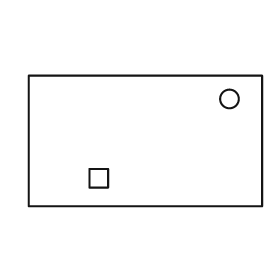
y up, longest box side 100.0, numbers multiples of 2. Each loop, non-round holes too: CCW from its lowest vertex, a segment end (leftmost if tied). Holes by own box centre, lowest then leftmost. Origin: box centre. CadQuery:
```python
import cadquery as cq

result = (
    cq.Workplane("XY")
    .moveTo(-50.0, -28.0)
    .lineTo(50.0, -28.0)
    .lineTo(50.0, 28.0)
    .lineTo(-50.0, 28.0)
    .close()
    .moveTo(-24.0, -20.0)
    .lineTo(-16.0, -20.0)
    .lineTo(-16.0, -12.0)
    .lineTo(-24.0, -12.0)
    .close()
    .moveTo(36.0, 18.0)
    .circle(4.0)
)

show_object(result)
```